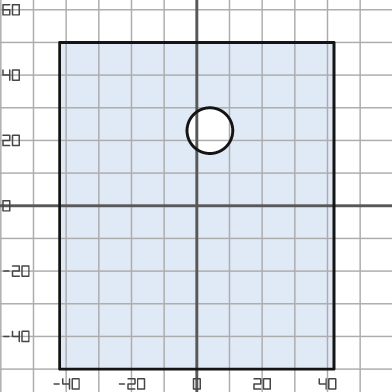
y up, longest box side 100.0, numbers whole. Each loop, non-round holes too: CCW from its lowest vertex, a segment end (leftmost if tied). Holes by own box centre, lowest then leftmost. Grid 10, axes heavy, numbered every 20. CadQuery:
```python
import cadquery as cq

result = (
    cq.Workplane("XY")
    .moveTo(-42.0, -50.0)
    .lineTo(42.0, -50.0)
    .lineTo(42.0, 50.0)
    .lineTo(-42.0, 50.0)
    .close()
    .moveTo(4.0, 23.0)
    .circle(7.0)
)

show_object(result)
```